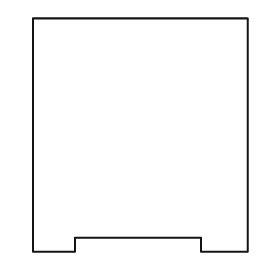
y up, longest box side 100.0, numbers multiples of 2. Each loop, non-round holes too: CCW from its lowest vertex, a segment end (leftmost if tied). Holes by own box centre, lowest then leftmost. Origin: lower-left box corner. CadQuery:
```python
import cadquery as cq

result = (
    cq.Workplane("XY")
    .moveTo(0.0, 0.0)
    .lineTo(18.0, 0.0)
    .lineTo(18.0, 6.0)
    .lineTo(72.0, 6.0)
    .lineTo(72.0, 0.0)
    .lineTo(92.0, 0.0)
    .lineTo(92.0, 100.0)
    .lineTo(0.0, 100.0)
    .close()
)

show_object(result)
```